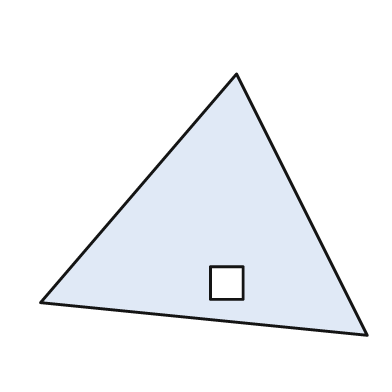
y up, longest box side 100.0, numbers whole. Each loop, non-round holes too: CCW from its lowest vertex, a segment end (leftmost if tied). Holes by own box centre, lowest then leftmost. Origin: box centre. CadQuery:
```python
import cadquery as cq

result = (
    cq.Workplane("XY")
    .moveTo(50.0, -40.0)
    .lineTo(10.0, 40.0)
    .lineTo(-50.0, -30.0)
    .close()
    .moveTo(2.0, -29.0)
    .lineTo(12.0, -29.0)
    .lineTo(12.0, -19.0)
    .lineTo(2.0, -19.0)
    .close()
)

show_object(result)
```